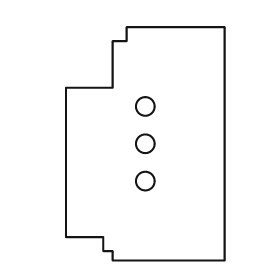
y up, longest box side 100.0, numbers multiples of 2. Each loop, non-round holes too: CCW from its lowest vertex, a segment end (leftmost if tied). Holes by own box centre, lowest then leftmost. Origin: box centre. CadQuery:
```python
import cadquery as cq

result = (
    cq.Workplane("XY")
    .moveTo(-14.0, -50.0)
    .lineTo(34.0, -50.0)
    .lineTo(34.0, 50.0)
    .lineTo(-8.0, 50.0)
    .lineTo(-8.0, 44.0)
    .lineTo(-14.0, 44.0)
    .lineTo(-14.0, 24.0)
    .lineTo(-34.0, 24.0)
    .lineTo(-34.0, -40.0)
    .lineTo(-18.0, -40.0)
    .lineTo(-18.0, -46.0)
    .lineTo(-14.0, -46.0)
    .close()
    .moveTo(0.0, -16.0)
    .circle(4.0)
    .moveTo(0.0, 0.0)
    .circle(4.0)
    .moveTo(0.0, 16.0)
    .circle(4.0)
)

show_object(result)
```